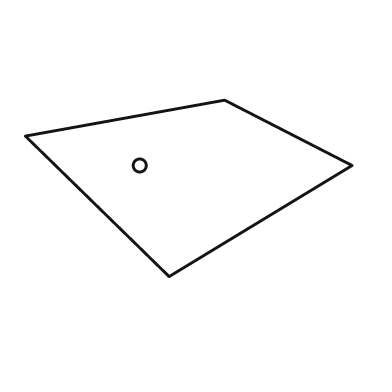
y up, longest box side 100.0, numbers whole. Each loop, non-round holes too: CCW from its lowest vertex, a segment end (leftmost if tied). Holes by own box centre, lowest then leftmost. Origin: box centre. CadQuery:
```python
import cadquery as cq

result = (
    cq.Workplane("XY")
    .moveTo(-6.0, -27.0)
    .lineTo(50.0, 7.0)
    .lineTo(11.0, 27.0)
    .lineTo(-50.0, 16.0)
    .close()
    .moveTo(-15.0, 7.0)
    .circle(2.0)
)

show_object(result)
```